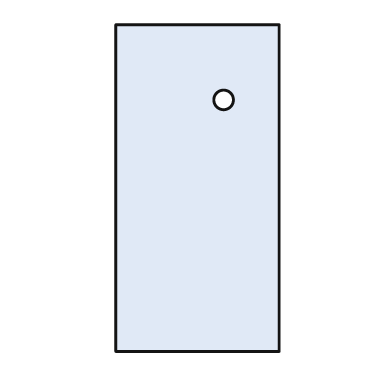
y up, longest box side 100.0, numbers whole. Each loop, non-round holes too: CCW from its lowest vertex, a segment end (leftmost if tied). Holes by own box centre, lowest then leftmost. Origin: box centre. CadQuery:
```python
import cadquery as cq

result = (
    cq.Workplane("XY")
    .moveTo(-25.0, -50.0)
    .lineTo(25.0, -50.0)
    .lineTo(25.0, 50.0)
    .lineTo(-25.0, 50.0)
    .close()
    .moveTo(8.0, 27.0)
    .circle(3.0)
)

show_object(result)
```